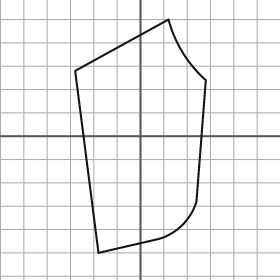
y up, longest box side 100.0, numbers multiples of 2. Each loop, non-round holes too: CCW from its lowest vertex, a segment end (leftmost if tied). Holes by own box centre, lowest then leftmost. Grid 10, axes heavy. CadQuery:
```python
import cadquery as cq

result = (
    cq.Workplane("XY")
    .moveTo(-18.0, -50.0)
    .lineTo(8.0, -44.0)
    .threePointArc((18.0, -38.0), (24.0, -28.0))
    .lineTo(28.0, 24.0)
    .threePointArc((18.0, 36.0), (12.0, 50.0))
    .lineTo(-28.0, 28.0)
    .close()
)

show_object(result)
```